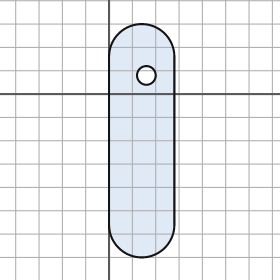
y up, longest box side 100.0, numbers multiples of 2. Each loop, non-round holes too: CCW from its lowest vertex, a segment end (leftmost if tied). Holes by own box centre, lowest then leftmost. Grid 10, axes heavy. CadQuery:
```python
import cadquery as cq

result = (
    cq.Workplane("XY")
    .moveTo(0.0, -56.0)
    .threePointArc((14.0, -70.0), (28.0, -56.0))
    .lineTo(28.0, 16.0)
    .threePointArc((14.0, 30.0), (0.0, 16.0))
    .close()
    .moveTo(16.0, 8.0)
    .circle(4.0)
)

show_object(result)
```